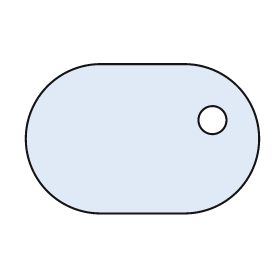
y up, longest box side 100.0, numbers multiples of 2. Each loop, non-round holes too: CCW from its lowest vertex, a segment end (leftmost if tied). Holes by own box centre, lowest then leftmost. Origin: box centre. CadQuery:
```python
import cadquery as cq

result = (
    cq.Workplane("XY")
    .moveTo(-18.0, -32.0)
    .lineTo(18.0, -32.0)
    .threePointArc((50.0, 0.0), (18.0, 32.0))
    .lineTo(-18.0, 32.0)
    .threePointArc((-50.0, 0.0), (-18.0, -32.0))
    .close()
    .moveTo(30.0, 8.0)
    .circle(6.0)
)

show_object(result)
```